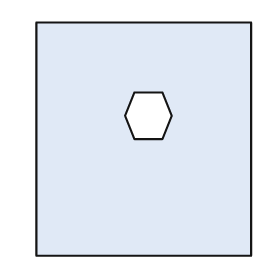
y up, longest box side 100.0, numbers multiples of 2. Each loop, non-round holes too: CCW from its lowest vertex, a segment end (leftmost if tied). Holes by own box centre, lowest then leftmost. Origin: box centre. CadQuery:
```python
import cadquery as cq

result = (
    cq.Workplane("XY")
    .moveTo(-46.0, -50.0)
    .lineTo(46.0, -50.0)
    .lineTo(46.0, 50.0)
    .lineTo(-46.0, 50.0)
    .close()
    .moveTo(-4.0, 0.0)
    .lineTo(8.0, 0.0)
    .lineTo(12.0, 10.0)
    .lineTo(8.0, 20.0)
    .lineTo(-4.0, 20.0)
    .lineTo(-8.0, 10.0)
    .close()
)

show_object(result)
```